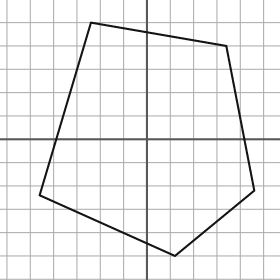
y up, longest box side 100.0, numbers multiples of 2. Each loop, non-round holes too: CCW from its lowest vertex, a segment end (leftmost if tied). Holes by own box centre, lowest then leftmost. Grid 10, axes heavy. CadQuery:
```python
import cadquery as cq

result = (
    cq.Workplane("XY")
    .moveTo(12.0, -50.0)
    .lineTo(46.0, -22.0)
    .lineTo(34.0, 40.0)
    .lineTo(-24.0, 50.0)
    .lineTo(-46.0, -24.0)
    .close()
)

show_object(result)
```